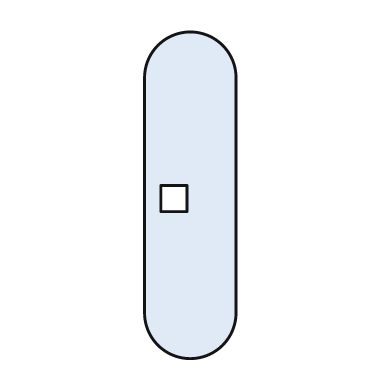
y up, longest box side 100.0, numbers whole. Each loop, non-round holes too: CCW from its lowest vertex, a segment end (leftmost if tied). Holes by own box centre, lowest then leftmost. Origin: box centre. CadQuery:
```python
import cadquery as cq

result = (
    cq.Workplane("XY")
    .moveTo(-14.0, -36.0)
    .threePointArc((0.0, -50.0), (14.0, -36.0))
    .lineTo(14.0, 36.0)
    .threePointArc((0.0, 50.0), (-14.0, 36.0))
    .close()
    .moveTo(-9.0, -5.0)
    .lineTo(-1.0, -5.0)
    .lineTo(-1.0, 3.0)
    .lineTo(-9.0, 3.0)
    .close()
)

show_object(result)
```